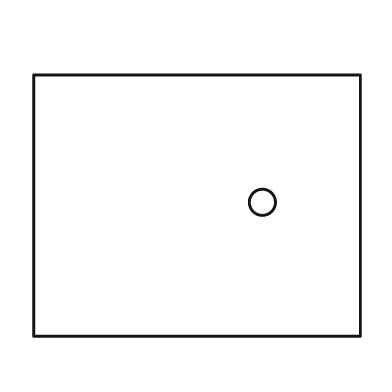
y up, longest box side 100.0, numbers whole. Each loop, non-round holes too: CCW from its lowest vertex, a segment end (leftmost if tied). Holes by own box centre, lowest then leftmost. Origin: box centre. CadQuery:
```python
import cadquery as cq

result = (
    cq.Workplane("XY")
    .moveTo(-50.0, -40.0)
    .lineTo(50.0, -40.0)
    .lineTo(50.0, 40.0)
    .lineTo(-50.0, 40.0)
    .close()
    .moveTo(20.0, 1.0)
    .circle(4.0)
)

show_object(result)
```